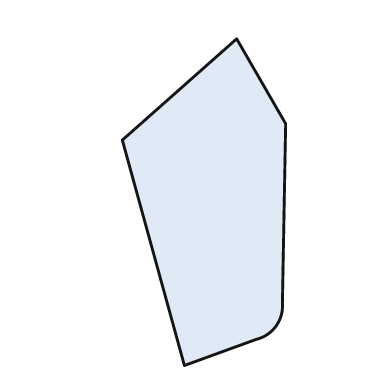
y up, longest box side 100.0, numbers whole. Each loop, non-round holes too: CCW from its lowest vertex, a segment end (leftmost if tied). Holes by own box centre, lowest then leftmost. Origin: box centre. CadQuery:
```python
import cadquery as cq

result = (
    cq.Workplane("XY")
    .moveTo(-6.0, -50.0)
    .lineTo(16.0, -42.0)
    .threePointArc((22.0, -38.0), (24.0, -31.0))
    .lineTo(25.0, 24.0)
    .lineTo(10.0, 50.0)
    .lineTo(-25.0, 19.0)
    .close()
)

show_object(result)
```